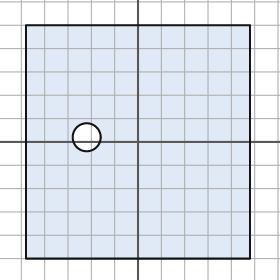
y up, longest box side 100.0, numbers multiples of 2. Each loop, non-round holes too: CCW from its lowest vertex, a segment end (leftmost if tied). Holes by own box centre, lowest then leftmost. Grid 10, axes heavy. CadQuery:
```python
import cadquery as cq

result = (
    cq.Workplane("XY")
    .moveTo(-48.0, -50.0)
    .lineTo(48.0, -50.0)
    .lineTo(48.0, 50.0)
    .lineTo(-48.0, 50.0)
    .close()
    .moveTo(-22.0, 2.0)
    .circle(6.0)
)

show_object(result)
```